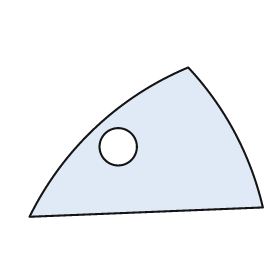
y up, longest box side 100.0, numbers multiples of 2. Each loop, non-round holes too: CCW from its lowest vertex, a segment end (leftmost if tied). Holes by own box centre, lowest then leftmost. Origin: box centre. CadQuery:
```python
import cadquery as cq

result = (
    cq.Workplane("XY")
    .moveTo(-50.0, -32.0)
    .lineTo(50.0, -28.0)
    .threePointArc((38.0, 4.0), (18.0, 32.0))
    .threePointArc((-22.0, 6.0), (-50.0, -32.0))
    .close()
    .moveTo(-12.0, -2.0)
    .circle(8.0)
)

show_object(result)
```